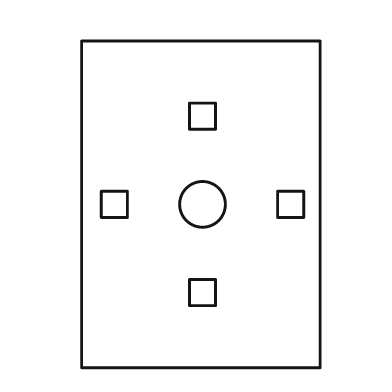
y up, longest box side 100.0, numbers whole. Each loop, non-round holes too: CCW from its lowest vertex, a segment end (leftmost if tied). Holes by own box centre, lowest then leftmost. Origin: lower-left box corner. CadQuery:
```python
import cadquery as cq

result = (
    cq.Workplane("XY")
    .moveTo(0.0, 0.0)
    .lineTo(73.0, 0.0)
    .lineTo(73.0, 100.0)
    .lineTo(0.0, 100.0)
    .close()
    .moveTo(33.0, 19.0)
    .lineTo(41.0, 19.0)
    .lineTo(41.0, 27.0)
    .lineTo(33.0, 27.0)
    .close()
    .moveTo(6.0, 46.0)
    .lineTo(14.0, 46.0)
    .lineTo(14.0, 54.0)
    .lineTo(6.0, 54.0)
    .close()
    .moveTo(37.0, 50.0)
    .circle(7.0)
    .moveTo(60.0, 46.0)
    .lineTo(68.0, 46.0)
    .lineTo(68.0, 54.0)
    .lineTo(60.0, 54.0)
    .close()
    .moveTo(33.0, 73.0)
    .lineTo(41.0, 73.0)
    .lineTo(41.0, 81.0)
    .lineTo(33.0, 81.0)
    .close()
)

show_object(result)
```